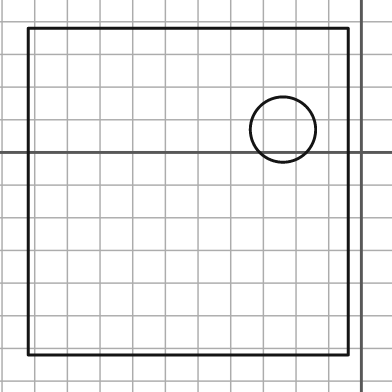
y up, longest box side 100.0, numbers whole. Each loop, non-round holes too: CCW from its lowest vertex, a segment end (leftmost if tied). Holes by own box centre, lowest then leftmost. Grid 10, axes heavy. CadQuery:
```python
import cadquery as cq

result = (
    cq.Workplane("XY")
    .moveTo(-102.0, -62.0)
    .lineTo(-4.0, -62.0)
    .lineTo(-4.0, 38.0)
    .lineTo(-102.0, 38.0)
    .close()
    .moveTo(-24.0, 7.0)
    .circle(10.0)
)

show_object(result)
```